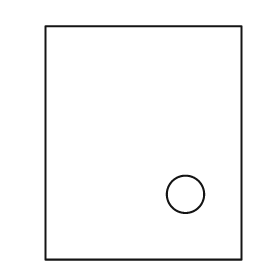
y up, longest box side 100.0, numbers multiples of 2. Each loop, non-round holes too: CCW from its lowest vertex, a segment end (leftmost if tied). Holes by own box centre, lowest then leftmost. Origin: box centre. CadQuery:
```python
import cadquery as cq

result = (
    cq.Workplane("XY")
    .moveTo(-42.0, -50.0)
    .lineTo(42.0, -50.0)
    .lineTo(42.0, 50.0)
    .lineTo(-42.0, 50.0)
    .close()
    .moveTo(18.0, -22.0)
    .circle(8.0)
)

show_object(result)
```